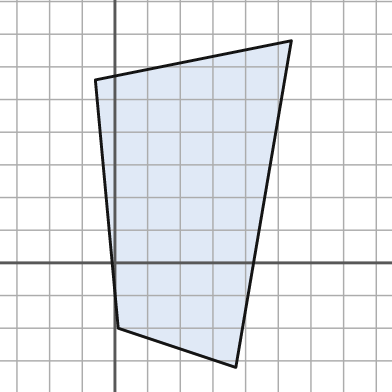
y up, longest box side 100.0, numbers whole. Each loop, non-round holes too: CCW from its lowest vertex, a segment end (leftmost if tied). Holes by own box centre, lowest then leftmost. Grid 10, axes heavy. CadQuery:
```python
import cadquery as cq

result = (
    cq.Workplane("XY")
    .moveTo(37.0, -32.0)
    .lineTo(54.0, 68.0)
    .lineTo(-6.0, 56.0)
    .lineTo(1.0, -20.0)
    .close()
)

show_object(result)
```